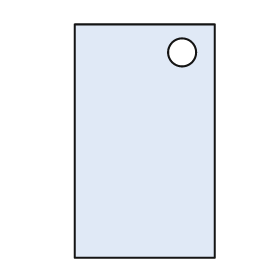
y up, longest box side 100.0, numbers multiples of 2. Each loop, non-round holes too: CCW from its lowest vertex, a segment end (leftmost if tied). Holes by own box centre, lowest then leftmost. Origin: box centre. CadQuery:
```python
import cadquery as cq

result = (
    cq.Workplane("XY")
    .moveTo(-30.0, -50.0)
    .lineTo(30.0, -50.0)
    .lineTo(30.0, 50.0)
    .lineTo(-30.0, 50.0)
    .close()
    .moveTo(16.0, 38.0)
    .circle(6.0)
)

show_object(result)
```